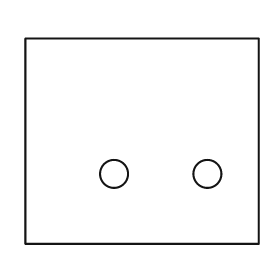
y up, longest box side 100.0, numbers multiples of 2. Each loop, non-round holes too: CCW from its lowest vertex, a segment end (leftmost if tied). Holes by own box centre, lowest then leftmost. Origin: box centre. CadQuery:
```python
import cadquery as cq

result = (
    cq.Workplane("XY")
    .moveTo(-50.0, -44.0)
    .lineTo(50.0, -44.0)
    .lineTo(50.0, 44.0)
    .lineTo(-50.0, 44.0)
    .close()
    .moveTo(-12.0, -14.0)
    .circle(6.0)
    .moveTo(28.0, -14.0)
    .circle(6.0)
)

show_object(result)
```